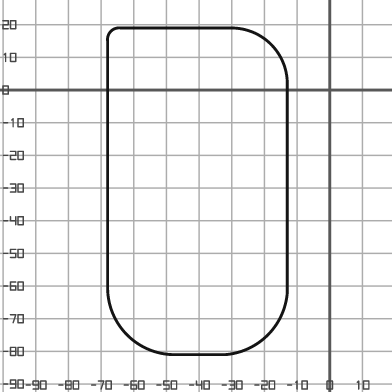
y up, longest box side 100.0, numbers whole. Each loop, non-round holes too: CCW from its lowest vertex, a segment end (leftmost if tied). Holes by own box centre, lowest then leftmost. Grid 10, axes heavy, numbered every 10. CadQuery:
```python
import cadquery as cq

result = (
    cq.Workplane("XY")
    .moveTo(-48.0, -81.0)
    .lineTo(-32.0, -81.0)
    .threePointArc((-19.0, -75.0), (-13.0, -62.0))
    .lineTo(-13.0, 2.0)
    .threePointArc((-18.0, 14.0), (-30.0, 19.0))
    .lineTo(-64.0, 19.0)
    .threePointArc((-67.0, 18.0), (-68.0, 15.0))
    .lineTo(-68.0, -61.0)
    .threePointArc((-62.0, -75.0), (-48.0, -81.0))
    .close()
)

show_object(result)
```